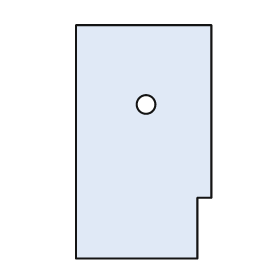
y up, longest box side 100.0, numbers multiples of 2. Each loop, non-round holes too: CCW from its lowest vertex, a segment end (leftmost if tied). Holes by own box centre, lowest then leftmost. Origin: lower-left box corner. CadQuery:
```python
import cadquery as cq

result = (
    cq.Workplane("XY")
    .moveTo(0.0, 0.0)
    .lineTo(52.0, 0.0)
    .lineTo(52.0, 26.0)
    .lineTo(58.0, 26.0)
    .lineTo(58.0, 100.0)
    .lineTo(0.0, 100.0)
    .close()
    .moveTo(30.0, 66.0)
    .circle(4.0)
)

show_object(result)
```